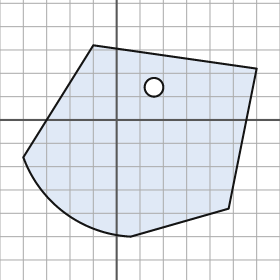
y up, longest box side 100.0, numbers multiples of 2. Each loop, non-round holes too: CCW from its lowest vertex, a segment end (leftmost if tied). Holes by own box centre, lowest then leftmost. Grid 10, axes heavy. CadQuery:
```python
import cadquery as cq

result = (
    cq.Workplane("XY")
    .moveTo(6.0, -50.0)
    .lineTo(48.0, -38.0)
    .lineTo(60.0, 22.0)
    .lineTo(-10.0, 32.0)
    .lineTo(-40.0, -16.0)
    .threePointArc((-22.0, -40.0), (6.0, -50.0))
    .close()
    .moveTo(16.0, 14.0)
    .circle(4.0)
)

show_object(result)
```